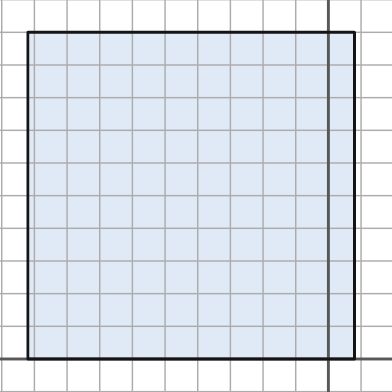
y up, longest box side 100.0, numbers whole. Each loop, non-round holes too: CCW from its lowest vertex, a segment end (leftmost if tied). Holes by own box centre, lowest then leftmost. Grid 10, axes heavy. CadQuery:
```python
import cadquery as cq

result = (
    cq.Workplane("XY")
    .moveTo(-92.0, 0.0)
    .lineTo(8.0, 0.0)
    .lineTo(8.0, 100.0)
    .lineTo(-92.0, 100.0)
    .close()
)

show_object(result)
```